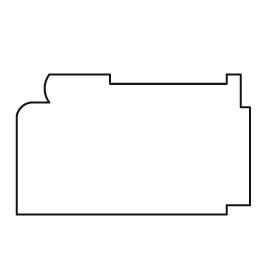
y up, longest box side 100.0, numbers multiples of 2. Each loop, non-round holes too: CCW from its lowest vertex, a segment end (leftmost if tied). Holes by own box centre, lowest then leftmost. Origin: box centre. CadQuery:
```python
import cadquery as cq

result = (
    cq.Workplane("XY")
    .moveTo(-50.0, -30.0)
    .lineTo(40.0, -30.0)
    .lineTo(40.0, -26.0)
    .lineTo(50.0, -26.0)
    .lineTo(50.0, 16.0)
    .lineTo(46.0, 16.0)
    .lineTo(46.0, 30.0)
    .lineTo(40.0, 30.0)
    .lineTo(40.0, 26.0)
    .lineTo(-10.0, 26.0)
    .lineTo(-10.0, 30.0)
    .lineTo(-36.0, 30.0)
    .threePointArc((-38.0, 24.0), (-36.0, 18.0))
    .lineTo(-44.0, 18.0)
    .threePointArc((-48.0, 16.0), (-50.0, 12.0))
    .close()
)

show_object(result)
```